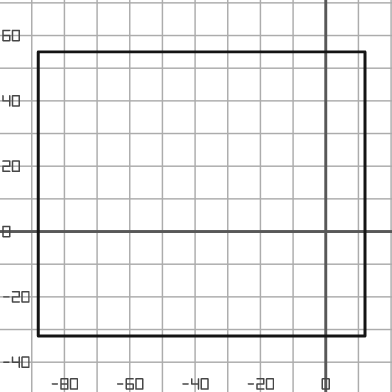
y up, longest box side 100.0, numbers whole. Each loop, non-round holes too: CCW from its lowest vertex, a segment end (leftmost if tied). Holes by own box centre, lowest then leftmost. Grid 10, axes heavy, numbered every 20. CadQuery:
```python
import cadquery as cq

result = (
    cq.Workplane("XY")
    .moveTo(-88.0, -32.0)
    .lineTo(12.0, -32.0)
    .lineTo(12.0, 55.0)
    .lineTo(-88.0, 55.0)
    .close()
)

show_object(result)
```